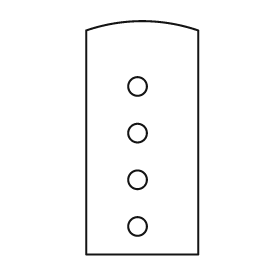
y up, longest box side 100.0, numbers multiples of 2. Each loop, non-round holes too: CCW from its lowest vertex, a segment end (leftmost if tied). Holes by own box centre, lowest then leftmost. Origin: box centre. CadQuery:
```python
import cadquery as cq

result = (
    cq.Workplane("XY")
    .moveTo(-24.0, -50.0)
    .lineTo(24.0, -50.0)
    .lineTo(24.0, 46.0)
    .threePointArc((0.0, 50.0), (-24.0, 46.0))
    .close()
    .moveTo(-2.0, -38.0)
    .circle(4.0)
    .moveTo(-2.0, -18.0)
    .circle(4.0)
    .moveTo(-2.0, 2.0)
    .circle(4.0)
    .moveTo(-2.0, 22.0)
    .circle(4.0)
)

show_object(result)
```